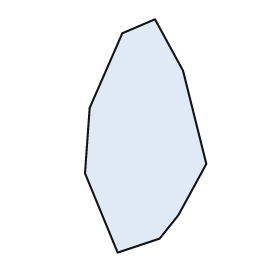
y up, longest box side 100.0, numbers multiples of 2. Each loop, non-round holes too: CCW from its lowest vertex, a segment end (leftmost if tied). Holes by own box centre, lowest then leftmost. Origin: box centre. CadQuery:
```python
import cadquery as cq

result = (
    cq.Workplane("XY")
    .moveTo(-12.0, -50.0)
    .lineTo(6.0, -44.0)
    .lineTo(14.0, -34.0)
    .lineTo(26.0, -12.0)
    .lineTo(16.0, 28.0)
    .lineTo(4.0, 50.0)
    .lineTo(-10.0, 44.0)
    .lineTo(-24.0, 12.0)
    .lineTo(-26.0, -16.0)
    .close()
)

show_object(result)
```